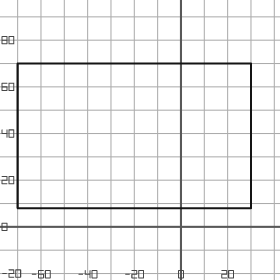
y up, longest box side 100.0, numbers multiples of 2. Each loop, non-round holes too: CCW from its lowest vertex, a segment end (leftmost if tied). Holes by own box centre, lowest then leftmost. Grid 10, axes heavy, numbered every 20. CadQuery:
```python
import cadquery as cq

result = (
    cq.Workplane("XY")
    .moveTo(-70.0, 8.0)
    .lineTo(30.0, 8.0)
    .lineTo(30.0, 70.0)
    .lineTo(-70.0, 70.0)
    .close()
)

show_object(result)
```